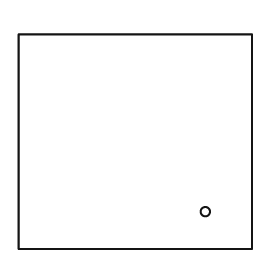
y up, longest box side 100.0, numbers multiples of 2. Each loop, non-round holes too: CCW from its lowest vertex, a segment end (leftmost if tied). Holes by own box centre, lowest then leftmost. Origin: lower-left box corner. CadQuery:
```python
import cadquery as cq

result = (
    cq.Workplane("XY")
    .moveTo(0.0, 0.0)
    .lineTo(100.0, 0.0)
    .lineTo(100.0, 92.0)
    .lineTo(0.0, 92.0)
    .close()
    .moveTo(80.0, 16.0)
    .circle(2.0)
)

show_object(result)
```